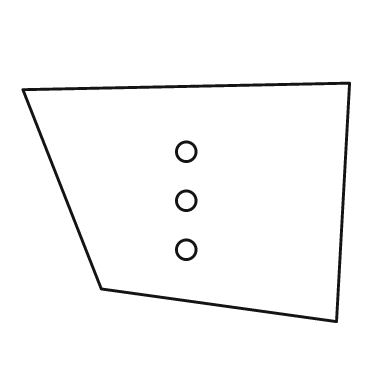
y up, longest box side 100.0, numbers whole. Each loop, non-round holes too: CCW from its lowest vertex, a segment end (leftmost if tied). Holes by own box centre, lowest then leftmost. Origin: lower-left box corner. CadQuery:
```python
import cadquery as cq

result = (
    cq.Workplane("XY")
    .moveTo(96.0, 0.0)
    .lineTo(100.0, 73.0)
    .lineTo(0.0, 71.0)
    .lineTo(24.0, 10.0)
    .close()
    .moveTo(50.0, 22.0)
    .circle(3.0)
    .moveTo(50.0, 37.0)
    .circle(3.0)
    .moveTo(50.0, 52.0)
    .circle(3.0)
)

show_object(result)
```